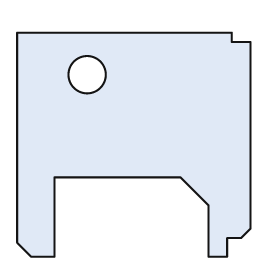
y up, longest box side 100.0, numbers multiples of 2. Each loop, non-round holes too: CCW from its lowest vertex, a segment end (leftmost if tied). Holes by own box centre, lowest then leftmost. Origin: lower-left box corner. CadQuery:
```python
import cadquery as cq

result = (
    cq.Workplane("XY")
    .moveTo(6.0, 0.0)
    .lineTo(16.0, 0.0)
    .lineTo(16.0, 34.0)
    .lineTo(70.0, 34.0)
    .lineTo(82.0, 22.0)
    .lineTo(82.0, 0.0)
    .lineTo(90.0, 0.0)
    .lineTo(90.0, 8.0)
    .lineTo(96.0, 8.0)
    .lineTo(100.0, 12.0)
    .lineTo(100.0, 92.0)
    .lineTo(92.0, 92.0)
    .lineTo(92.0, 96.0)
    .lineTo(0.0, 96.0)
    .lineTo(0.0, 6.0)
    .close()
    .moveTo(30.0, 78.0)
    .circle(8.0)
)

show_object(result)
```